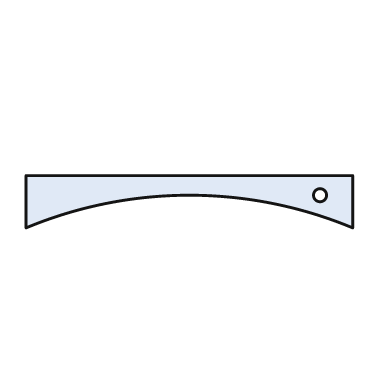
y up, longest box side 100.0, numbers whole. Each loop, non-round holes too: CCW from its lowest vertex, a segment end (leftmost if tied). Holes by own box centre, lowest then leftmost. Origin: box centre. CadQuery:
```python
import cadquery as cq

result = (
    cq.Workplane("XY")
    .moveTo(-50.0, -8.0)
    .threePointArc((0.0, 2.0), (50.0, -8.0))
    .lineTo(50.0, 8.0)
    .lineTo(-50.0, 8.0)
    .close()
    .moveTo(40.0, 2.0)
    .circle(2.0)
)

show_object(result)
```